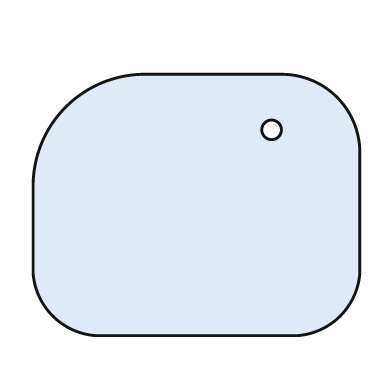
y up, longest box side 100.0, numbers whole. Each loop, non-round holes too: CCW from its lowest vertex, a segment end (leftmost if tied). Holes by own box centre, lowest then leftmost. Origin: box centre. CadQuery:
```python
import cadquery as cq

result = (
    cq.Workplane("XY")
    .moveTo(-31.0, -40.0)
    .lineTo(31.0, -40.0)
    .threePointArc((44.0, -34.0), (50.0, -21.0))
    .lineTo(50.0, 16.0)
    .threePointArc((43.0, 33.0), (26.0, 40.0))
    .lineTo(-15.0, 40.0)
    .threePointArc((-40.0, 30.0), (-50.0, 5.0))
    .lineTo(-50.0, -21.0)
    .threePointArc((-44.0, -34.0), (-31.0, -40.0))
    .close()
    .moveTo(23.0, 23.0)
    .circle(3.0)
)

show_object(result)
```